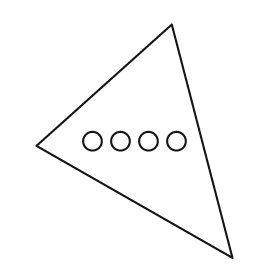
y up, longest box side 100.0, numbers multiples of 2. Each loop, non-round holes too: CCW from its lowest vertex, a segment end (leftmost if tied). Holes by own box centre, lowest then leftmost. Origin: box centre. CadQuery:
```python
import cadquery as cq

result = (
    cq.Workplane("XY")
    .moveTo(42.0, -50.0)
    .lineTo(16.0, 50.0)
    .lineTo(-42.0, -2.0)
    .close()
    .moveTo(-18.0, 0.0)
    .circle(4.0)
    .moveTo(-6.0, 0.0)
    .circle(4.0)
    .moveTo(6.0, 0.0)
    .circle(4.0)
    .moveTo(18.0, 0.0)
    .circle(4.0)
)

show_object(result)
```